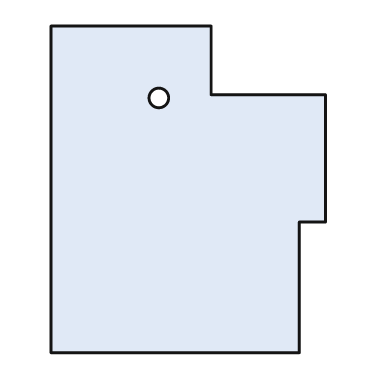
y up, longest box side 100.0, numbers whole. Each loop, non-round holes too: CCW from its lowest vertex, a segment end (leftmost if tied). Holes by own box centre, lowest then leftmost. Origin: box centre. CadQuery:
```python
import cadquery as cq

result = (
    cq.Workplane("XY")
    .moveTo(-42.0, -50.0)
    .lineTo(34.0, -50.0)
    .lineTo(34.0, -10.0)
    .lineTo(42.0, -10.0)
    .lineTo(42.0, 29.0)
    .lineTo(7.0, 29.0)
    .lineTo(7.0, 50.0)
    .lineTo(-42.0, 50.0)
    .close()
    .moveTo(-9.0, 28.0)
    .circle(3.0)
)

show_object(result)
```